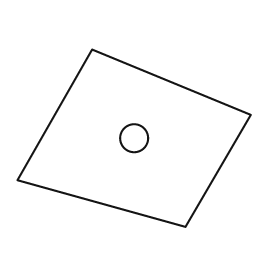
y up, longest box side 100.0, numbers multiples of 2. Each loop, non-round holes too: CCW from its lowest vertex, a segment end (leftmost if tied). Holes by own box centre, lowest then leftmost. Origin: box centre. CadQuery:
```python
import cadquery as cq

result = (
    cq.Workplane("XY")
    .moveTo(22.0, -38.0)
    .lineTo(50.0, 10.0)
    .lineTo(-18.0, 38.0)
    .lineTo(-50.0, -18.0)
    .close()
    .moveTo(0.0, 0.0)
    .circle(6.0)
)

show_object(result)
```